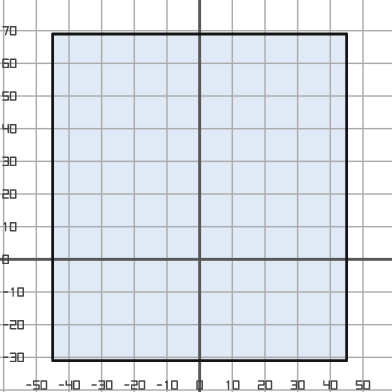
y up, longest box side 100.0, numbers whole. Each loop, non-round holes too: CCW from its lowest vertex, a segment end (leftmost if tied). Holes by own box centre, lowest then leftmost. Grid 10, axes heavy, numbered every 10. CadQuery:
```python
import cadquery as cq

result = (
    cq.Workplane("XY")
    .moveTo(-45.0, -31.0)
    .lineTo(45.0, -31.0)
    .lineTo(45.0, 69.0)
    .lineTo(-45.0, 69.0)
    .close()
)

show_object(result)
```